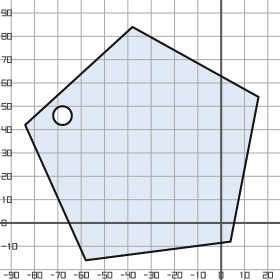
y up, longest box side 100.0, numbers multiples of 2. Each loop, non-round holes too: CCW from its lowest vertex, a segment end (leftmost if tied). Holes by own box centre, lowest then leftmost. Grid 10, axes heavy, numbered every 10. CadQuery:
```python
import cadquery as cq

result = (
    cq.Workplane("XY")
    .moveTo(-58.0, -16.0)
    .lineTo(4.0, -8.0)
    .lineTo(16.0, 54.0)
    .lineTo(-38.0, 84.0)
    .lineTo(-84.0, 42.0)
    .close()
    .moveTo(-68.0, 46.0)
    .circle(4.0)
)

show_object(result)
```